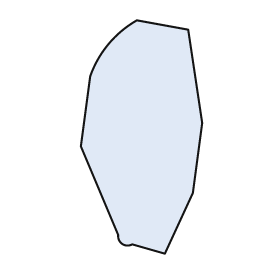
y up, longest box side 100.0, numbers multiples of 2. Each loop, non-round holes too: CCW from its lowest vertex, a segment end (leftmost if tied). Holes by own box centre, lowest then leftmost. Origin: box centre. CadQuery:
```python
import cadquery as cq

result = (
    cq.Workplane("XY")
    .moveTo(10.0, -50.0)
    .lineTo(22.0, -24.0)
    .lineTo(26.0, 6.0)
    .lineTo(20.0, 46.0)
    .lineTo(-2.0, 50.0)
    .threePointArc((-14.0, 40.0), (-22.0, 26.0))
    .lineTo(-26.0, -4.0)
    .lineTo(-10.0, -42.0)
    .threePointArc((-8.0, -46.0), (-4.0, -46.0))
    .close()
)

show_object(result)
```